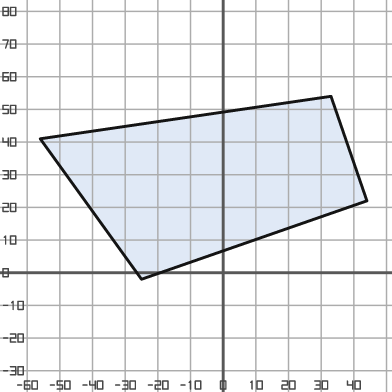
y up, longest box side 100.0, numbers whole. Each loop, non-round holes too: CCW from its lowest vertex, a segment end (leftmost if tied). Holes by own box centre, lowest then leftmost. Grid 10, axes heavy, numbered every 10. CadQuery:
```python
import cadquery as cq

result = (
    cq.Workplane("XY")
    .moveTo(-25.0, -2.0)
    .lineTo(44.0, 22.0)
    .lineTo(33.0, 54.0)
    .lineTo(-56.0, 41.0)
    .close()
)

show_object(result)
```